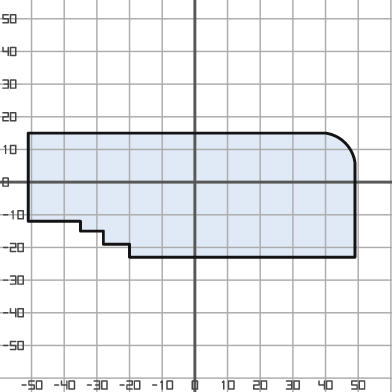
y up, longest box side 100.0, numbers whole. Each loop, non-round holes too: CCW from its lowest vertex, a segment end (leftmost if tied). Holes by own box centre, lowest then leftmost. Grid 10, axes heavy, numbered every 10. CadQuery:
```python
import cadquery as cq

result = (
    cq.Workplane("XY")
    .moveTo(-20.0, -23.0)
    .lineTo(49.0, -23.0)
    .lineTo(49.0, 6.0)
    .threePointArc((46.0, 12.0), (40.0, 15.0))
    .lineTo(-51.0, 15.0)
    .lineTo(-51.0, -12.0)
    .lineTo(-35.0, -12.0)
    .lineTo(-35.0, -15.0)
    .lineTo(-28.0, -15.0)
    .lineTo(-28.0, -19.0)
    .lineTo(-20.0, -19.0)
    .close()
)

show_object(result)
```